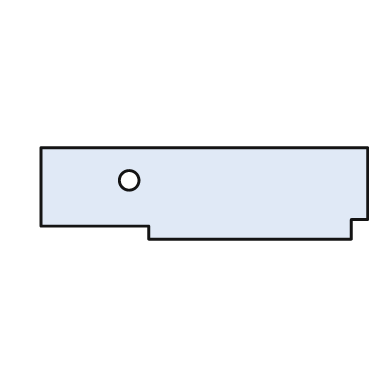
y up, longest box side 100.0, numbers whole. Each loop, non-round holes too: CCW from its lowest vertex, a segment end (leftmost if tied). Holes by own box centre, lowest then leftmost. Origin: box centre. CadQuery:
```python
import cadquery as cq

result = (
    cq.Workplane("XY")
    .moveTo(-17.0, -14.0)
    .lineTo(45.0, -14.0)
    .lineTo(45.0, -8.0)
    .lineTo(50.0, -8.0)
    .lineTo(50.0, 14.0)
    .lineTo(-50.0, 14.0)
    .lineTo(-50.0, -10.0)
    .lineTo(-17.0, -10.0)
    .close()
    .moveTo(-23.0, 4.0)
    .circle(3.0)
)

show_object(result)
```